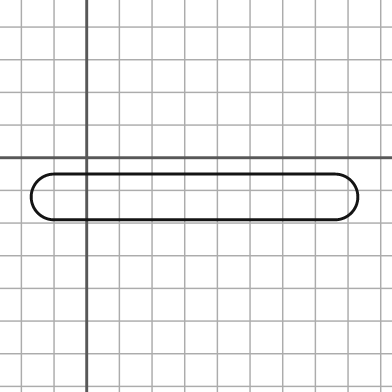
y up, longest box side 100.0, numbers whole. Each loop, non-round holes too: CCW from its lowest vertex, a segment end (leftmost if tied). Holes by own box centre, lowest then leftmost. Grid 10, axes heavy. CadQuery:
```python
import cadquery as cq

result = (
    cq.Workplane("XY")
    .moveTo(-10.0, -19.0)
    .lineTo(76.0, -19.0)
    .threePointArc((83.0, -12.0), (76.0, -5.0))
    .lineTo(-10.0, -5.0)
    .threePointArc((-17.0, -12.0), (-10.0, -19.0))
    .close()
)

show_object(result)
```